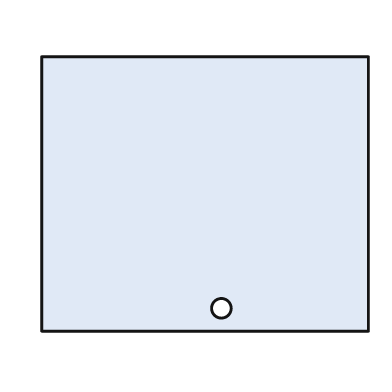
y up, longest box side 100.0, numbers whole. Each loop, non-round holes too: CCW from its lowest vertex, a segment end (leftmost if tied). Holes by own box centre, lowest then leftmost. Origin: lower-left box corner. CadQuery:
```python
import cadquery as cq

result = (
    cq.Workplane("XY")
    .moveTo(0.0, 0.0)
    .lineTo(100.0, 0.0)
    .lineTo(100.0, 84.0)
    .lineTo(0.0, 84.0)
    .close()
    .moveTo(55.0, 7.0)
    .circle(3.0)
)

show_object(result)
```